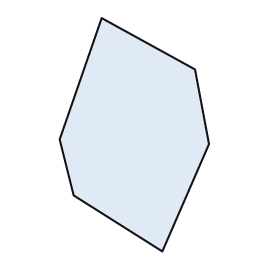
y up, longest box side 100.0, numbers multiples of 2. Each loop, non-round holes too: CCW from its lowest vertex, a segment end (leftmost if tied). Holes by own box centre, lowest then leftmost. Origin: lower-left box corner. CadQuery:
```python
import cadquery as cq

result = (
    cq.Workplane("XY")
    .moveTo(44.0, 0.0)
    .lineTo(64.0, 46.0)
    .lineTo(58.0, 78.0)
    .lineTo(18.0, 100.0)
    .lineTo(0.0, 48.0)
    .lineTo(6.0, 24.0)
    .close()
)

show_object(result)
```